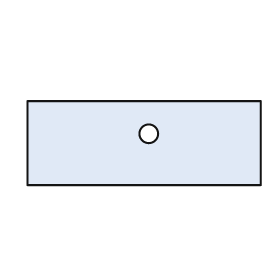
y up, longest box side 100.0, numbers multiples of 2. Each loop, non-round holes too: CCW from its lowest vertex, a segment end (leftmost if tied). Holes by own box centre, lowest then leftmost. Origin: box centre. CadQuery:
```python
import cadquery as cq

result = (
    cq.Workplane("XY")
    .moveTo(-50.0, -18.0)
    .lineTo(50.0, -18.0)
    .lineTo(50.0, 18.0)
    .lineTo(-50.0, 18.0)
    .close()
    .moveTo(2.0, 4.0)
    .circle(4.0)
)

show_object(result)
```